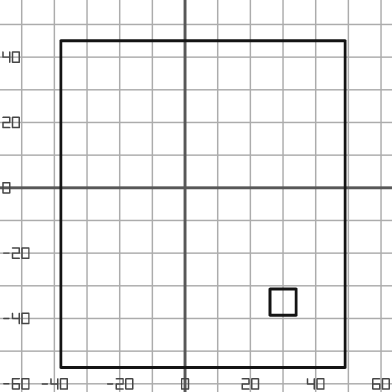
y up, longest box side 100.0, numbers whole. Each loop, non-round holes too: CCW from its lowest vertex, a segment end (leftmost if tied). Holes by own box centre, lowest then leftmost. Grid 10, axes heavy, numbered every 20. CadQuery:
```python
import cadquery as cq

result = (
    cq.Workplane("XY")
    .moveTo(-38.0, -55.0)
    .lineTo(49.0, -55.0)
    .lineTo(49.0, 45.0)
    .lineTo(-38.0, 45.0)
    .close()
    .moveTo(26.0, -39.0)
    .lineTo(34.0, -39.0)
    .lineTo(34.0, -31.0)
    .lineTo(26.0, -31.0)
    .close()
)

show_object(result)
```